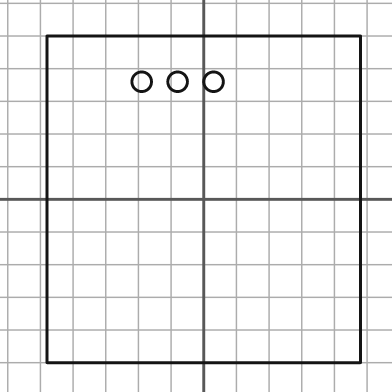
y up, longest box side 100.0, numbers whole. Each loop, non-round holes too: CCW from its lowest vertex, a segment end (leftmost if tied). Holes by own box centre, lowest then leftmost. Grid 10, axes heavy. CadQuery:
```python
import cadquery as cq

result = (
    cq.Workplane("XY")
    .moveTo(-48.0, -50.0)
    .lineTo(48.0, -50.0)
    .lineTo(48.0, 50.0)
    .lineTo(-48.0, 50.0)
    .close()
    .moveTo(-19.0, 36.0)
    .circle(3.0)
    .moveTo(-8.0, 36.0)
    .circle(3.0)
    .moveTo(3.0, 36.0)
    .circle(3.0)
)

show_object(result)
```